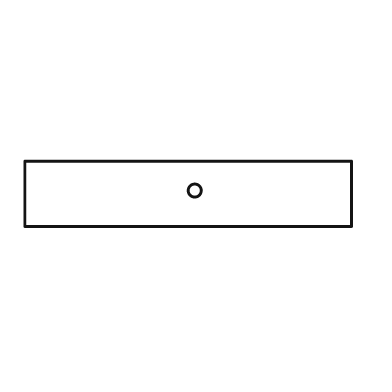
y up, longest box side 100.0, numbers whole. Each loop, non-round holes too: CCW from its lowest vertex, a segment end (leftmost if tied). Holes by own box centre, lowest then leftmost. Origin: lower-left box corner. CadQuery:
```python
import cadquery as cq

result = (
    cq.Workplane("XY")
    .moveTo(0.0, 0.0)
    .lineTo(100.0, 0.0)
    .lineTo(100.0, 20.0)
    .lineTo(0.0, 20.0)
    .close()
    .moveTo(52.0, 11.0)
    .circle(2.0)
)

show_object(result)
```